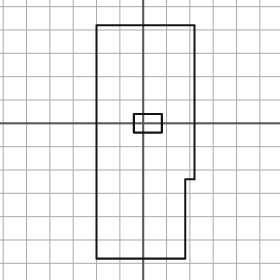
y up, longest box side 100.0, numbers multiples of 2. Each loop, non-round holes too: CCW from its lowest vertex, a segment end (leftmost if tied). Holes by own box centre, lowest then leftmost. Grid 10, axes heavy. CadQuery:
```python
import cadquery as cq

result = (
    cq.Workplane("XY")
    .moveTo(-20.0, -58.0)
    .lineTo(18.0, -58.0)
    .lineTo(18.0, -24.0)
    .lineTo(22.0, -24.0)
    .lineTo(22.0, 42.0)
    .lineTo(-20.0, 42.0)
    .close()
    .moveTo(-4.0, -4.0)
    .lineTo(8.0, -4.0)
    .lineTo(8.0, 4.0)
    .lineTo(-4.0, 4.0)
    .close()
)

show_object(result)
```